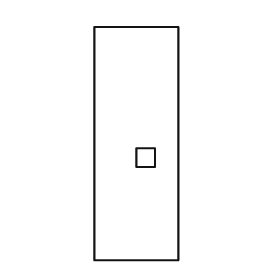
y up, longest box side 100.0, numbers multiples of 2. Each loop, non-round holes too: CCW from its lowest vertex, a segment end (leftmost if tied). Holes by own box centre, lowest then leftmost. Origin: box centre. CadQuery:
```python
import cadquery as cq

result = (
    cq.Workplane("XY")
    .moveTo(-18.0, -50.0)
    .lineTo(18.0, -50.0)
    .lineTo(18.0, 50.0)
    .lineTo(-18.0, 50.0)
    .close()
    .moveTo(0.0, -10.0)
    .lineTo(8.0, -10.0)
    .lineTo(8.0, -2.0)
    .lineTo(0.0, -2.0)
    .close()
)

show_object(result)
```